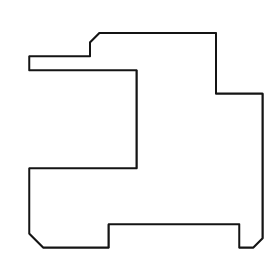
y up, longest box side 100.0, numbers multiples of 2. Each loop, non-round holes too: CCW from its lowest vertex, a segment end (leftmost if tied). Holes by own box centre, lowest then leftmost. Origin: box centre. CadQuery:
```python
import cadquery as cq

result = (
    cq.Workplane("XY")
    .moveTo(-44.0, -46.0)
    .lineTo(-16.0, -46.0)
    .lineTo(-16.0, -36.0)
    .lineTo(40.0, -36.0)
    .lineTo(40.0, -46.0)
    .lineTo(46.0, -46.0)
    .lineTo(50.0, -42.0)
    .lineTo(50.0, 20.0)
    .lineTo(30.0, 20.0)
    .lineTo(30.0, 46.0)
    .lineTo(-20.0, 46.0)
    .lineTo(-24.0, 42.0)
    .lineTo(-24.0, 36.0)
    .lineTo(-50.0, 36.0)
    .lineTo(-50.0, 30.0)
    .lineTo(-4.0, 30.0)
    .lineTo(-4.0, -12.0)
    .lineTo(-50.0, -12.0)
    .lineTo(-50.0, -40.0)
    .close()
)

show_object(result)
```